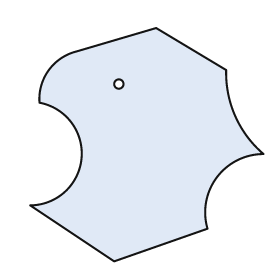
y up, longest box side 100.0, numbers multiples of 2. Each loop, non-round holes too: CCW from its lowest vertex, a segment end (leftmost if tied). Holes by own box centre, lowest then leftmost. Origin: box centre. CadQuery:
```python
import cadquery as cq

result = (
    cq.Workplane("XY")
    .moveTo(-14.0, -50.0)
    .lineTo(26.0, -36.0)
    .threePointArc((30.0, -14.0), (50.0, -4.0))
    .threePointArc((38.0, 12.0), (34.0, 32.0))
    .lineTo(4.0, 50.0)
    .lineTo(-30.0, 40.0)
    .threePointArc((-42.0, 32.0), (-46.0, 18.0))
    .threePointArc((-28.0, -6.0), (-50.0, -26.0))
    .close()
    .moveTo(-12.0, 26.0)
    .circle(2.0)
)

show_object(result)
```